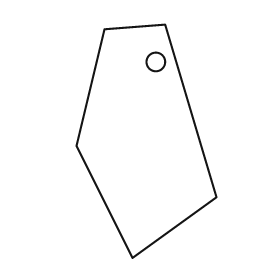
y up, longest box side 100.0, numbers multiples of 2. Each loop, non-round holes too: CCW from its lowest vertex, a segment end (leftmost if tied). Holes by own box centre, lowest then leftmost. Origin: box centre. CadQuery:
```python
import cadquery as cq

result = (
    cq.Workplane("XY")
    .moveTo(-6.0, -50.0)
    .lineTo(30.0, -24.0)
    .lineTo(8.0, 50.0)
    .lineTo(-18.0, 48.0)
    .lineTo(-30.0, -2.0)
    .close()
    .moveTo(4.0, 34.0)
    .circle(4.0)
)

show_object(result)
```